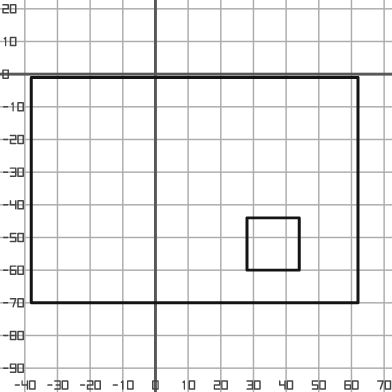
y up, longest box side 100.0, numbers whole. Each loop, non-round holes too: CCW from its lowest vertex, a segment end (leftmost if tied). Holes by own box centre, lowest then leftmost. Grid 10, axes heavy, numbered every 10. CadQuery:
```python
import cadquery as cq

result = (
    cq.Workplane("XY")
    .moveTo(-38.0, -70.0)
    .lineTo(62.0, -70.0)
    .lineTo(62.0, -1.0)
    .lineTo(-38.0, -1.0)
    .close()
    .moveTo(28.0, -60.0)
    .lineTo(44.0, -60.0)
    .lineTo(44.0, -44.0)
    .lineTo(28.0, -44.0)
    .close()
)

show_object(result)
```